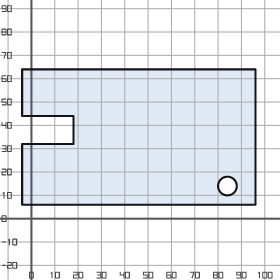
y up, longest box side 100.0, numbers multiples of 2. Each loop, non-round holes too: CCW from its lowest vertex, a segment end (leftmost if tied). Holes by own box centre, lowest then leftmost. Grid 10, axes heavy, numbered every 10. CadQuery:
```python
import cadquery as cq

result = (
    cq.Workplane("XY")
    .moveTo(-4.0, 6.0)
    .lineTo(96.0, 6.0)
    .lineTo(96.0, 64.0)
    .lineTo(-4.0, 64.0)
    .lineTo(-4.0, 44.0)
    .lineTo(18.0, 44.0)
    .lineTo(18.0, 32.0)
    .lineTo(-4.0, 32.0)
    .close()
    .moveTo(84.0, 14.0)
    .circle(4.0)
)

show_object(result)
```